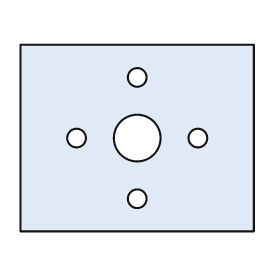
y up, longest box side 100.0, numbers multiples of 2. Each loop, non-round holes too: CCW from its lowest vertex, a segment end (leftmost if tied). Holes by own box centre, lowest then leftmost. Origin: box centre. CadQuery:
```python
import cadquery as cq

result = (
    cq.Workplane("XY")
    .moveTo(-50.0, -40.0)
    .lineTo(50.0, -40.0)
    .lineTo(50.0, 40.0)
    .lineTo(-50.0, 40.0)
    .close()
    .moveTo(0.0, -26.0)
    .circle(4.0)
    .moveTo(-26.0, 0.0)
    .circle(4.0)
    .moveTo(0.0, 0.0)
    .circle(10.0)
    .moveTo(26.0, 0.0)
    .circle(4.0)
    .moveTo(0.0, 26.0)
    .circle(4.0)
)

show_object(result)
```